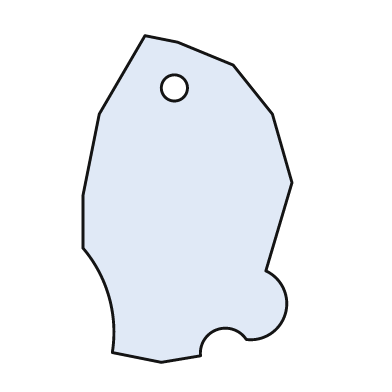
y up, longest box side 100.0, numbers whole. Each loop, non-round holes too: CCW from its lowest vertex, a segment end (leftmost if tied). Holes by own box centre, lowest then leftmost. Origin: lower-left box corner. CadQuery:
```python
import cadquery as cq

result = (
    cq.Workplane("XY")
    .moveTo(24.0, 0.0)
    .lineTo(36.0, 2.0)
    .threePointArc((41.0, 10.0), (50.0, 7.0))
    .threePointArc((62.0, 15.0), (56.0, 28.0))
    .lineTo(64.0, 55.0)
    .lineTo(58.0, 76.0)
    .lineTo(46.0, 91.0)
    .lineTo(29.0, 98.0)
    .lineTo(19.0, 100.0)
    .lineTo(5.0, 76.0)
    .lineTo(0.0, 51.0)
    .lineTo(0.0, 35.0)
    .threePointArc((8.0, 20.0), (9.0, 3.0))
    .close()
    .moveTo(28.0, 84.0)
    .circle(4.0)
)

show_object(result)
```